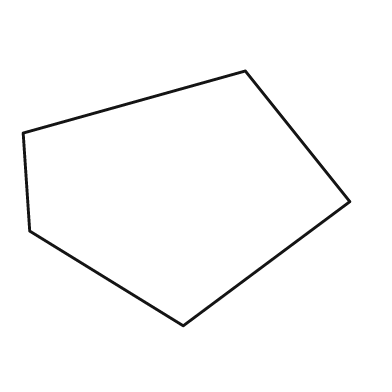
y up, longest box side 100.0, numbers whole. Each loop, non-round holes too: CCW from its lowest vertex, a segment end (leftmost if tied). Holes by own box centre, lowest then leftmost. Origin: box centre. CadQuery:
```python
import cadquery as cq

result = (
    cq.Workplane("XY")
    .moveTo(-1.0, -39.0)
    .lineTo(50.0, -1.0)
    .lineTo(18.0, 39.0)
    .lineTo(-50.0, 20.0)
    .lineTo(-48.0, -10.0)
    .close()
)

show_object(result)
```